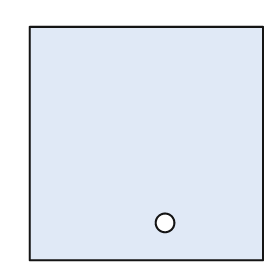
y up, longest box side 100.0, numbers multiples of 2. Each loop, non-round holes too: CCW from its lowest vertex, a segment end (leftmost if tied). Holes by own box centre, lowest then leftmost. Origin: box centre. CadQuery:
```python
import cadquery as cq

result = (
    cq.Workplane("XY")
    .moveTo(-50.0, -50.0)
    .lineTo(50.0, -50.0)
    .lineTo(50.0, 50.0)
    .lineTo(-50.0, 50.0)
    .close()
    .moveTo(8.0, -34.0)
    .circle(4.0)
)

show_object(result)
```